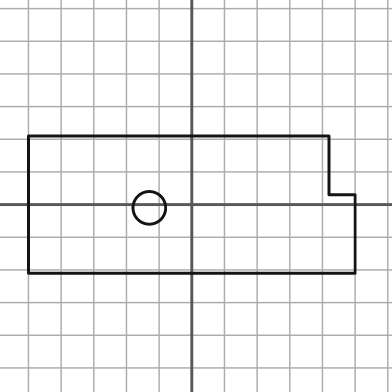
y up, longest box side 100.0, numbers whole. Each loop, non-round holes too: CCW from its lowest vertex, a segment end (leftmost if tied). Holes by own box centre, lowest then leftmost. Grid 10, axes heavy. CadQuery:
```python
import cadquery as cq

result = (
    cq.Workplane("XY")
    .moveTo(-50.0, -21.0)
    .lineTo(50.0, -21.0)
    .lineTo(50.0, 3.0)
    .lineTo(42.0, 3.0)
    .lineTo(42.0, 21.0)
    .lineTo(-50.0, 21.0)
    .close()
    .moveTo(-13.0, -1.0)
    .circle(5.0)
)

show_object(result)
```